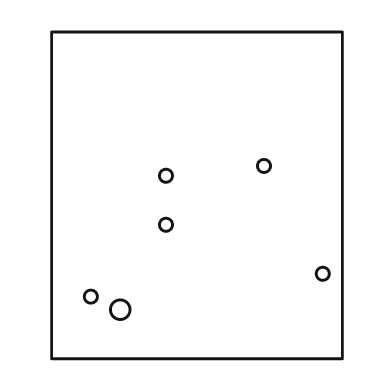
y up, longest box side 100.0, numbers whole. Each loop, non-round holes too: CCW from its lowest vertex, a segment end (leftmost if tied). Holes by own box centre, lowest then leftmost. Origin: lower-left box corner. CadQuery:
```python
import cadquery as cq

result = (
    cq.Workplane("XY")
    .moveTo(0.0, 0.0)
    .lineTo(89.0, 0.0)
    .lineTo(89.0, 100.0)
    .lineTo(0.0, 100.0)
    .close()
    .moveTo(21.0, 15.0)
    .circle(3.0)
    .moveTo(12.0, 19.0)
    .circle(2.0)
    .moveTo(83.0, 26.0)
    .circle(2.0)
    .moveTo(35.0, 41.0)
    .circle(2.0)
    .moveTo(35.0, 56.0)
    .circle(2.0)
    .moveTo(65.0, 59.0)
    .circle(2.0)
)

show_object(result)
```